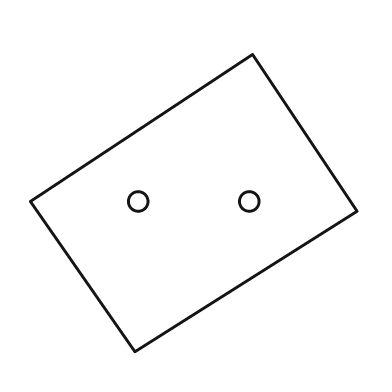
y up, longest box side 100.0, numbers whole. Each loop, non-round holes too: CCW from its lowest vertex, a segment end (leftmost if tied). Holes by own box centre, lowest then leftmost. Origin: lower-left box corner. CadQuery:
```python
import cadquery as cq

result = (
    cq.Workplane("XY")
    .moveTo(32.0, 0.0)
    .lineTo(100.0, 43.0)
    .lineTo(68.0, 91.0)
    .lineTo(0.0, 46.0)
    .close()
    .moveTo(33.0, 46.0)
    .circle(3.0)
    .moveTo(67.0, 46.0)
    .circle(3.0)
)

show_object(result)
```